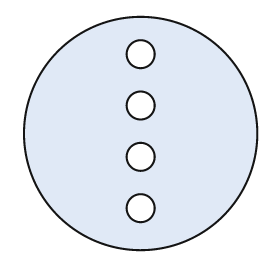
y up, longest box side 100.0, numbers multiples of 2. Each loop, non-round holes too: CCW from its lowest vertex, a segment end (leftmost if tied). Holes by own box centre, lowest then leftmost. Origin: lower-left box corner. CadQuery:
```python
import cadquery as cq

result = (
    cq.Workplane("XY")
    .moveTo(50.0, 50.0)
    .circle(50.0)
    .moveTo(50.0, 18.0)
    .circle(6.0)
    .moveTo(50.0, 40.0)
    .circle(6.0)
    .moveTo(50.0, 62.0)
    .circle(6.0)
    .moveTo(50.0, 84.0)
    .circle(6.0)
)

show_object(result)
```